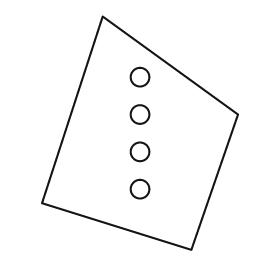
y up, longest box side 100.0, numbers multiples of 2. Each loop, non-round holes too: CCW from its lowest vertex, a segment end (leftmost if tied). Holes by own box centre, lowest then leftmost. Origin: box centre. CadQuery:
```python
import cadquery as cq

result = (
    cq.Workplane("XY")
    .moveTo(22.0, -50.0)
    .lineTo(42.0, 8.0)
    .lineTo(-16.0, 50.0)
    .lineTo(-42.0, -30.0)
    .close()
    .moveTo(0.0, -24.0)
    .circle(4.0)
    .moveTo(0.0, -8.0)
    .circle(4.0)
    .moveTo(0.0, 8.0)
    .circle(4.0)
    .moveTo(0.0, 24.0)
    .circle(4.0)
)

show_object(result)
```